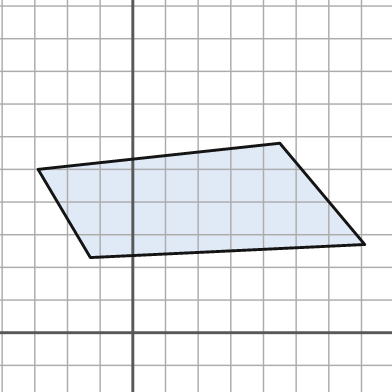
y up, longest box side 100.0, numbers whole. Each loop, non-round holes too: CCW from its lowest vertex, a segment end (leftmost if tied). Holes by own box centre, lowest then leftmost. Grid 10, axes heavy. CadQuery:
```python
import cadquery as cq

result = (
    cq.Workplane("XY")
    .moveTo(-13.0, 23.0)
    .lineTo(71.0, 27.0)
    .lineTo(45.0, 58.0)
    .lineTo(-29.0, 50.0)
    .close()
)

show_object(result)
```